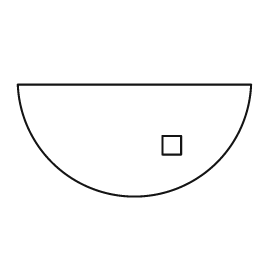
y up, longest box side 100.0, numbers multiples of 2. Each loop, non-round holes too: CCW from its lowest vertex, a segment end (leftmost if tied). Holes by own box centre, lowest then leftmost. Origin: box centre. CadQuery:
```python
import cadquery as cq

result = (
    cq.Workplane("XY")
    .moveTo(-50.0, 24.0)
    .threePointArc((0.0, -24.0), (50.0, 24.0))
    .close()
    .moveTo(12.0, -6.0)
    .lineTo(20.0, -6.0)
    .lineTo(20.0, 2.0)
    .lineTo(12.0, 2.0)
    .close()
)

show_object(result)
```